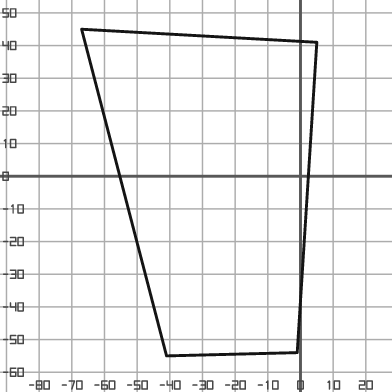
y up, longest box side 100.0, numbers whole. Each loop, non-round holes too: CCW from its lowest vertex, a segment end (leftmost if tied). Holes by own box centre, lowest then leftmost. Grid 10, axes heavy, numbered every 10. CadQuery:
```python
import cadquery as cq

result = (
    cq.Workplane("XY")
    .moveTo(-41.0, -55.0)
    .lineTo(-1.0, -54.0)
    .lineTo(5.0, 41.0)
    .lineTo(-67.0, 45.0)
    .close()
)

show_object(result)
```